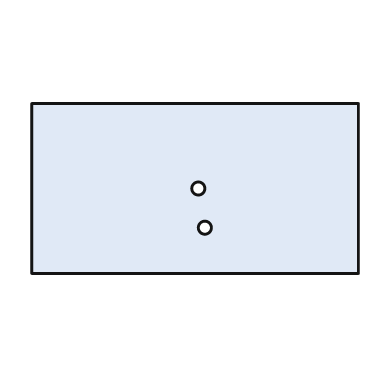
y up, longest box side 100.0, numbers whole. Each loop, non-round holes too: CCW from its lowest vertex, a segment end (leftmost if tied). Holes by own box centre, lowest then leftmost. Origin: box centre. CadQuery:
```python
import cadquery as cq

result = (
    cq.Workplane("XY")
    .moveTo(-50.0, -26.0)
    .lineTo(50.0, -26.0)
    .lineTo(50.0, 26.0)
    .lineTo(-50.0, 26.0)
    .close()
    .moveTo(3.0, -12.0)
    .circle(2.0)
    .moveTo(1.0, 0.0)
    .circle(2.0)
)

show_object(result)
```